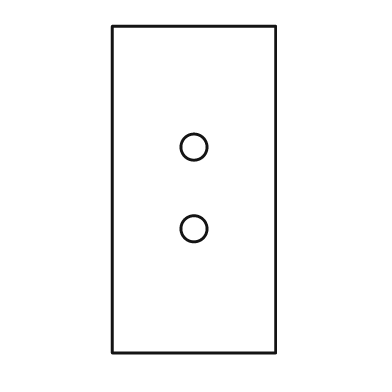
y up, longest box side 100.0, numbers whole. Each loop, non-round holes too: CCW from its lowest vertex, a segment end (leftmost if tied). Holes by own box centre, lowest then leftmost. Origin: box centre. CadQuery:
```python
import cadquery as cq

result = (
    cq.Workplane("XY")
    .moveTo(-25.0, -50.0)
    .lineTo(25.0, -50.0)
    .lineTo(25.0, 50.0)
    .lineTo(-25.0, 50.0)
    .close()
    .moveTo(0.0, -12.0)
    .circle(4.0)
    .moveTo(0.0, 13.0)
    .circle(4.0)
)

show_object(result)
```